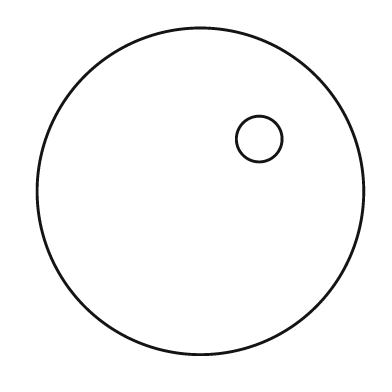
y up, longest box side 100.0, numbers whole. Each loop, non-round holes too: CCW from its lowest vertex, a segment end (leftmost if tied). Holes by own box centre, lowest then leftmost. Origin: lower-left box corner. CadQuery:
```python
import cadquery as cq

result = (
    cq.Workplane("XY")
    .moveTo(50.0, 50.0)
    .circle(50.0)
    .moveTo(68.0, 66.0)
    .circle(7.0)
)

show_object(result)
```